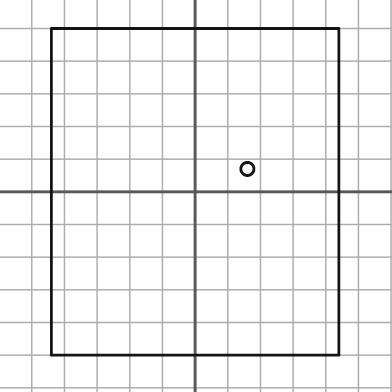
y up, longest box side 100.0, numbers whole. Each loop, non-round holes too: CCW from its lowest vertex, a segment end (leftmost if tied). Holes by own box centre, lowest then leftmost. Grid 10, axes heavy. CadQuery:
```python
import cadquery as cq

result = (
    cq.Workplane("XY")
    .moveTo(-44.0, -50.0)
    .lineTo(44.0, -50.0)
    .lineTo(44.0, 50.0)
    .lineTo(-44.0, 50.0)
    .close()
    .moveTo(16.0, 7.0)
    .circle(2.0)
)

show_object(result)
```